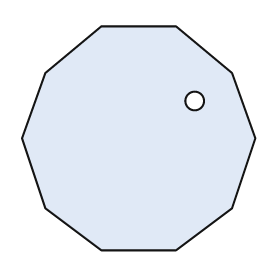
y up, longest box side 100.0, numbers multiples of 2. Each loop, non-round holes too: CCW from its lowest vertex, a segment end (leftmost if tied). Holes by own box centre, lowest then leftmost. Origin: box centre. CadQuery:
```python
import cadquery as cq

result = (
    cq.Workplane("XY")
    .moveTo(-16.0, -48.0)
    .lineTo(16.0, -48.0)
    .lineTo(40.0, -30.0)
    .lineTo(50.0, 0.0)
    .lineTo(40.0, 28.0)
    .lineTo(16.0, 48.0)
    .lineTo(-16.0, 48.0)
    .lineTo(-40.0, 28.0)
    .lineTo(-50.0, 0.0)
    .lineTo(-40.0, -30.0)
    .close()
    .moveTo(24.0, 16.0)
    .circle(4.0)
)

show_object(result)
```